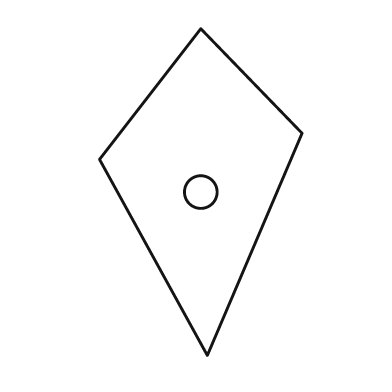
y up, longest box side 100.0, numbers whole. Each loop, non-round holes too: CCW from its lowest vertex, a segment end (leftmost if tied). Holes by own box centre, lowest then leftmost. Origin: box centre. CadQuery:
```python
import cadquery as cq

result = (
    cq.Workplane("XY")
    .moveTo(2.0, -50.0)
    .lineTo(31.0, 18.0)
    .lineTo(0.0, 50.0)
    .lineTo(-31.0, 10.0)
    .close()
    .moveTo(0.0, 0.0)
    .circle(5.0)
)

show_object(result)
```